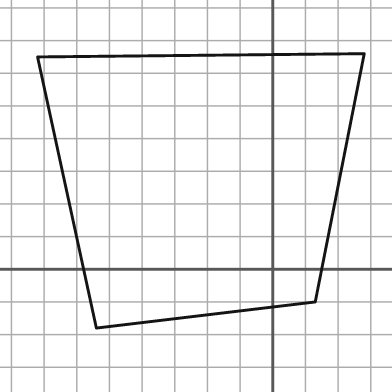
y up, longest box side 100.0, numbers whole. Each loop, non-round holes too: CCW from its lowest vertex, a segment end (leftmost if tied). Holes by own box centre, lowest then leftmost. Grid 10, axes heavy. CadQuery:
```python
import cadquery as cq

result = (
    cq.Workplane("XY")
    .moveTo(-54.0, -18.0)
    .lineTo(13.0, -10.0)
    .lineTo(28.0, 66.0)
    .lineTo(-72.0, 65.0)
    .close()
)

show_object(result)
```